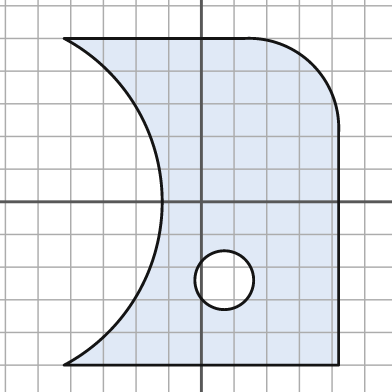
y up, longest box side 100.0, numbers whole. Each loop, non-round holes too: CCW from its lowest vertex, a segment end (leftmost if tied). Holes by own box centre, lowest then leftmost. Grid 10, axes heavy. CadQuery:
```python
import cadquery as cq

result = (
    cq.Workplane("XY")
    .moveTo(-42.0, -50.0)
    .lineTo(42.0, -50.0)
    .lineTo(42.0, 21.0)
    .threePointArc((34.0, 42.0), (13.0, 50.0))
    .lineTo(-42.0, 50.0)
    .threePointArc((-12.0, 0.0), (-42.0, -50.0))
    .close()
    .moveTo(7.0, -24.0)
    .circle(9.0)
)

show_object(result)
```